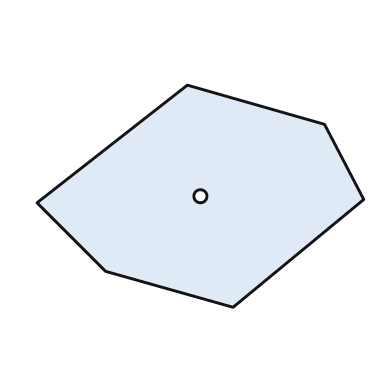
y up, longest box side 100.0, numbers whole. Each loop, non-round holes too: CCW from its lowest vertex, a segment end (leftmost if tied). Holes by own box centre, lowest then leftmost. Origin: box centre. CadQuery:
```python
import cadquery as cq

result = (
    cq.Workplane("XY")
    .moveTo(10.0, -34.0)
    .lineTo(50.0, -1.0)
    .lineTo(38.0, 22.0)
    .lineTo(-4.0, 34.0)
    .lineTo(-50.0, -2.0)
    .lineTo(-29.0, -23.0)
    .close()
    .moveTo(0.0, 0.0)
    .circle(2.0)
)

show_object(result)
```